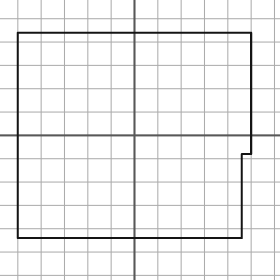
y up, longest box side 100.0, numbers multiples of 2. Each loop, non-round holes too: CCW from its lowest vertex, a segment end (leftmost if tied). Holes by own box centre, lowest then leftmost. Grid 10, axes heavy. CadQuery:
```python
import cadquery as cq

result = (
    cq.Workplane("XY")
    .moveTo(-50.0, -44.0)
    .lineTo(46.0, -44.0)
    .lineTo(46.0, -8.0)
    .lineTo(50.0, -8.0)
    .lineTo(50.0, 44.0)
    .lineTo(-50.0, 44.0)
    .close()
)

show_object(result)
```